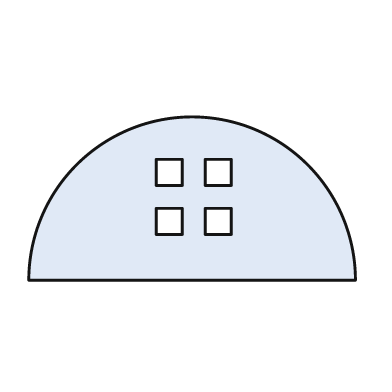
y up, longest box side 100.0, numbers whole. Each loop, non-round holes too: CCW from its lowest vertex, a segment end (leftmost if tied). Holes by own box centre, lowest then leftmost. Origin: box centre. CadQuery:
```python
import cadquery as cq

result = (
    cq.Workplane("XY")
    .moveTo(-50.0, -25.0)
    .lineTo(50.0, -25.0)
    .threePointArc((0.0, 25.0), (-50.0, -25.0))
    .close()
    .moveTo(-11.0, -11.0)
    .lineTo(-3.0, -11.0)
    .lineTo(-3.0, -3.0)
    .lineTo(-11.0, -3.0)
    .close()
    .moveTo(4.0, -11.0)
    .lineTo(12.0, -11.0)
    .lineTo(12.0, -3.0)
    .lineTo(4.0, -3.0)
    .close()
    .moveTo(-11.0, 4.0)
    .lineTo(-3.0, 4.0)
    .lineTo(-3.0, 12.0)
    .lineTo(-11.0, 12.0)
    .close()
    .moveTo(4.0, 4.0)
    .lineTo(12.0, 4.0)
    .lineTo(12.0, 12.0)
    .lineTo(4.0, 12.0)
    .close()
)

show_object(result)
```